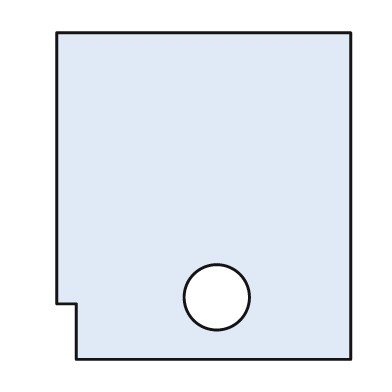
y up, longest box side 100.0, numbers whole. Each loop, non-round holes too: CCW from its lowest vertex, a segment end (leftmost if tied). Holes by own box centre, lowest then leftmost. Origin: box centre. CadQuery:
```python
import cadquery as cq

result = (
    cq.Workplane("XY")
    .moveTo(-39.0, -50.0)
    .lineTo(45.0, -50.0)
    .lineTo(45.0, 50.0)
    .lineTo(-45.0, 50.0)
    .lineTo(-45.0, -33.0)
    .lineTo(-39.0, -33.0)
    .close()
    .moveTo(4.0, -31.0)
    .circle(10.0)
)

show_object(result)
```